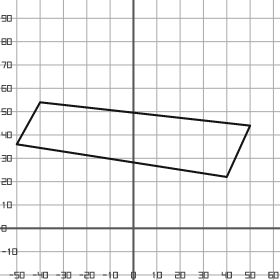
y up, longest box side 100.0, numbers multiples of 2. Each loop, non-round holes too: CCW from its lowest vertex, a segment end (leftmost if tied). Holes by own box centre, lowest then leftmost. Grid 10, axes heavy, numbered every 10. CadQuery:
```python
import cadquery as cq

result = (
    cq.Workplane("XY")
    .moveTo(40.0, 22.0)
    .lineTo(50.0, 44.0)
    .lineTo(-40.0, 54.0)
    .lineTo(-50.0, 36.0)
    .close()
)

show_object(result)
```